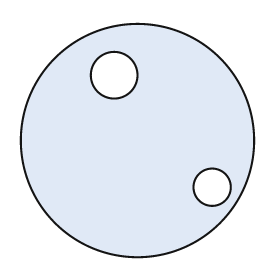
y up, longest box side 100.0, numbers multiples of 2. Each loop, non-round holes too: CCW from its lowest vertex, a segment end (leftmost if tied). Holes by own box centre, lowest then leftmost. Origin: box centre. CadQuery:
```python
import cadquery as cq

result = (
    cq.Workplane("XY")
    .moveTo(0.0, 0.0)
    .circle(50.0)
    .moveTo(32.0, -20.0)
    .circle(8.0)
    .moveTo(-10.0, 28.0)
    .circle(10.0)
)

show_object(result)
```